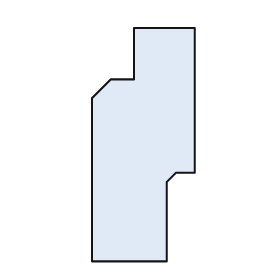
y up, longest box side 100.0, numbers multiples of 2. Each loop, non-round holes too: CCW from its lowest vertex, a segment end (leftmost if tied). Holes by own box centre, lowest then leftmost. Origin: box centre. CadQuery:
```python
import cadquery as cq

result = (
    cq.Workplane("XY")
    .moveTo(-22.0, -50.0)
    .lineTo(10.0, -50.0)
    .lineTo(10.0, -16.0)
    .lineTo(14.0, -12.0)
    .lineTo(22.0, -12.0)
    .lineTo(22.0, 50.0)
    .lineTo(-4.0, 50.0)
    .lineTo(-4.0, 28.0)
    .lineTo(-14.0, 28.0)
    .lineTo(-22.0, 20.0)
    .close()
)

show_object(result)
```